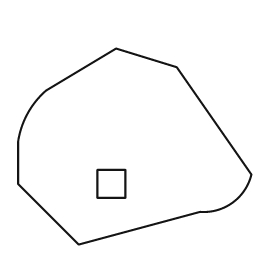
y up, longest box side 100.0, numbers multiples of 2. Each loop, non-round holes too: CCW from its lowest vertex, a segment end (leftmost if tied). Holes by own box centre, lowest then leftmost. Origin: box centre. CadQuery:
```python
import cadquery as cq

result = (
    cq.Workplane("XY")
    .moveTo(-24.0, -42.0)
    .lineTo(28.0, -28.0)
    .threePointArc((42.0, -24.0), (50.0, -12.0))
    .lineTo(18.0, 34.0)
    .lineTo(-8.0, 42.0)
    .lineTo(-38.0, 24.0)
    .threePointArc((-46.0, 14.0), (-50.0, 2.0))
    .lineTo(-50.0, -16.0)
    .close()
    .moveTo(-16.0, -22.0)
    .lineTo(-4.0, -22.0)
    .lineTo(-4.0, -10.0)
    .lineTo(-16.0, -10.0)
    .close()
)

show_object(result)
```